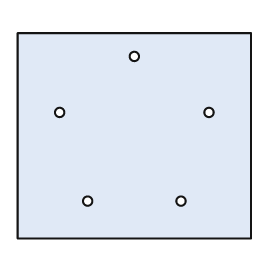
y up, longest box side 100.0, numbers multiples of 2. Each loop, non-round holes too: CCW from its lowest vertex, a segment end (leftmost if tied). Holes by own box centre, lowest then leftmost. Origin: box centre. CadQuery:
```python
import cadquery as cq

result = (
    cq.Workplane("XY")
    .moveTo(-50.0, -44.0)
    .lineTo(50.0, -44.0)
    .lineTo(50.0, 44.0)
    .lineTo(-50.0, 44.0)
    .close()
    .moveTo(-20.0, -28.0)
    .circle(2.0)
    .moveTo(20.0, -28.0)
    .circle(2.0)
    .moveTo(-32.0, 10.0)
    .circle(2.0)
    .moveTo(32.0, 10.0)
    .circle(2.0)
    .moveTo(0.0, 34.0)
    .circle(2.0)
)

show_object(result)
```